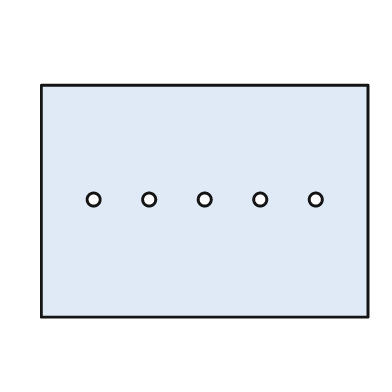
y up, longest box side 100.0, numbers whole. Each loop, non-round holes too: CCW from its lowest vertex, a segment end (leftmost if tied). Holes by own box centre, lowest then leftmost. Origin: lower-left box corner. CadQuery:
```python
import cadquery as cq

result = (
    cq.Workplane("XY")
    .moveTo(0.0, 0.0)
    .lineTo(100.0, 0.0)
    .lineTo(100.0, 71.0)
    .lineTo(0.0, 71.0)
    .close()
    .moveTo(16.0, 36.0)
    .circle(2.0)
    .moveTo(33.0, 36.0)
    .circle(2.0)
    .moveTo(50.0, 36.0)
    .circle(2.0)
    .moveTo(67.0, 36.0)
    .circle(2.0)
    .moveTo(84.0, 36.0)
    .circle(2.0)
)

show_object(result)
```